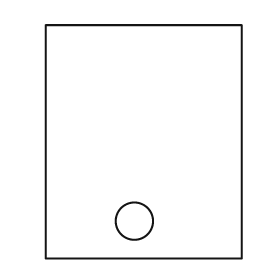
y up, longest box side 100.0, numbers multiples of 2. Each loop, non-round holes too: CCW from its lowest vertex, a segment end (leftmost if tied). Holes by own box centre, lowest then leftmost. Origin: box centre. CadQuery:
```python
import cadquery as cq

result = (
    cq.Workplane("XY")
    .moveTo(-42.0, -50.0)
    .lineTo(42.0, -50.0)
    .lineTo(42.0, 50.0)
    .lineTo(-42.0, 50.0)
    .close()
    .moveTo(-4.0, -34.0)
    .circle(8.0)
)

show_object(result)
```